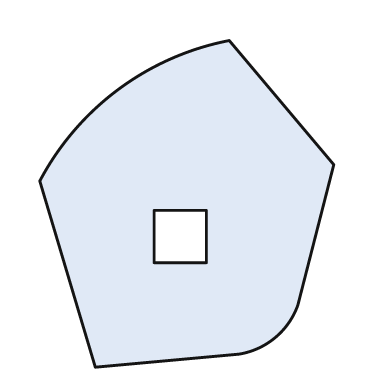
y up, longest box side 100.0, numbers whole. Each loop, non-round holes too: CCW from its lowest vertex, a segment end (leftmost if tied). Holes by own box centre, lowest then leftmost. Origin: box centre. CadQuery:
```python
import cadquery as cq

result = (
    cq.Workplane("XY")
    .moveTo(-28.0, -50.0)
    .lineTo(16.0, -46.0)
    .threePointArc((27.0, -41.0), (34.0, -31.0))
    .lineTo(45.0, 12.0)
    .lineTo(13.0, 50.0)
    .threePointArc((-21.0, 35.0), (-45.0, 7.0))
    .close()
    .moveTo(-10.0, -18.0)
    .lineTo(6.0, -18.0)
    .lineTo(6.0, -2.0)
    .lineTo(-10.0, -2.0)
    .close()
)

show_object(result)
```